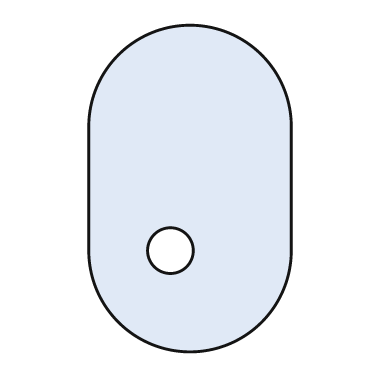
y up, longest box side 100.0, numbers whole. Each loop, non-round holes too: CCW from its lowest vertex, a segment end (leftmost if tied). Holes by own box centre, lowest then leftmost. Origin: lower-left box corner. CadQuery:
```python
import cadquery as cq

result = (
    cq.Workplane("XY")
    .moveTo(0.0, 31.0)
    .threePointArc((31.0, 0.0), (62.0, 31.0))
    .lineTo(62.0, 69.0)
    .threePointArc((31.0, 100.0), (0.0, 69.0))
    .close()
    .moveTo(25.0, 31.0)
    .circle(7.0)
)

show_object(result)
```